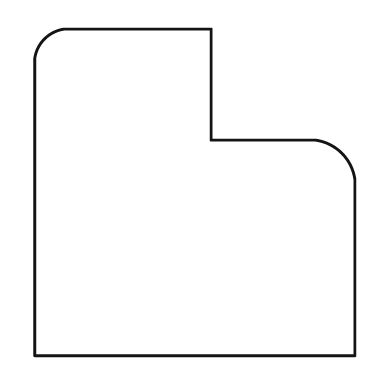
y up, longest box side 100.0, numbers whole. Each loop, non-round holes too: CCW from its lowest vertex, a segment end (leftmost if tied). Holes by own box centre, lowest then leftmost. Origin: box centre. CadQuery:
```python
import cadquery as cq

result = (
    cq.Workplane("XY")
    .moveTo(-49.0, -50.0)
    .lineTo(49.0, -50.0)
    .lineTo(49.0, 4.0)
    .threePointArc((45.0, 12.0), (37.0, 16.0))
    .lineTo(5.0, 16.0)
    .lineTo(5.0, 50.0)
    .lineTo(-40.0, 50.0)
    .threePointArc((-46.0, 47.0), (-49.0, 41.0))
    .close()
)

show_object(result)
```